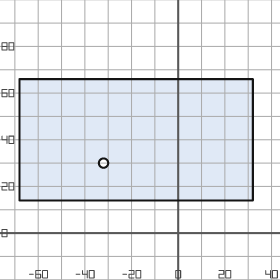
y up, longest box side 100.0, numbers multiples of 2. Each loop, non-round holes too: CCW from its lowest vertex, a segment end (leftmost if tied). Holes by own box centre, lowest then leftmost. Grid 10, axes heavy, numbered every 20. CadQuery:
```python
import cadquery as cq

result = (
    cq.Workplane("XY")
    .moveTo(-68.0, 14.0)
    .lineTo(32.0, 14.0)
    .lineTo(32.0, 66.0)
    .lineTo(-68.0, 66.0)
    .close()
    .moveTo(-32.0, 30.0)
    .circle(2.0)
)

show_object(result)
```